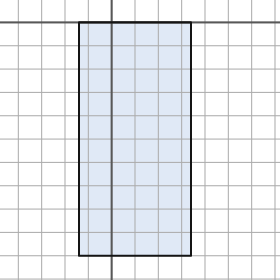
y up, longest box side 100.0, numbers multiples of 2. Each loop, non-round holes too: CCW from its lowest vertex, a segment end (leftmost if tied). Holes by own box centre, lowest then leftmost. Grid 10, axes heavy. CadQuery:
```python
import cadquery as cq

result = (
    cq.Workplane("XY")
    .moveTo(-14.0, -100.0)
    .lineTo(34.0, -100.0)
    .lineTo(34.0, 0.0)
    .lineTo(-14.0, 0.0)
    .close()
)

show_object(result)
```